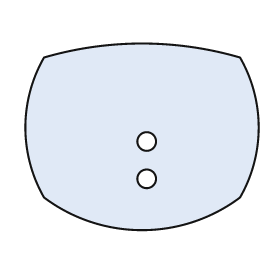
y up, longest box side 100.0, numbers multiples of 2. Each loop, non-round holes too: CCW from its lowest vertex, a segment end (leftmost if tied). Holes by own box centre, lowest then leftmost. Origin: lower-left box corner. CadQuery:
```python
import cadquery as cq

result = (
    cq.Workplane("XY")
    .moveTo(8.0, 14.0)
    .threePointArc((50.0, 0.0), (92.0, 14.0))
    .threePointArc((100.0, 44.0), (92.0, 74.0))
    .threePointArc((50.0, 80.0), (8.0, 74.0))
    .threePointArc((0.0, 44.0), (8.0, 14.0))
    .close()
    .moveTo(52.0, 22.0)
    .circle(4.0)
    .moveTo(52.0, 38.0)
    .circle(4.0)
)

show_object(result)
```